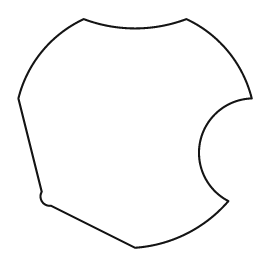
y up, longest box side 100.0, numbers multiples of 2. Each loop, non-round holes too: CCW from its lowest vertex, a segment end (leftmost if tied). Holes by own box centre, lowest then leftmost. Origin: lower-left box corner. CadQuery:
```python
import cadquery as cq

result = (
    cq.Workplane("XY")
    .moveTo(50.0, 0.0)
    .threePointArc((72.0, 6.0), (90.0, 20.0))
    .threePointArc((78.0, 46.0), (100.0, 64.0))
    .threePointArc((90.0, 84.0), (72.0, 98.0))
    .threePointArc((50.0, 94.0), (28.0, 98.0))
    .threePointArc((10.0, 84.0), (0.0, 64.0))
    .lineTo(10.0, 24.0)
    .threePointArc((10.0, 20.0), (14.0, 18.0))
    .close()
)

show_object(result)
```